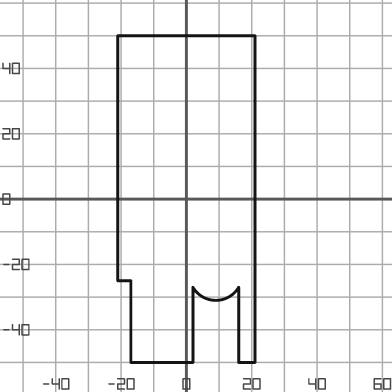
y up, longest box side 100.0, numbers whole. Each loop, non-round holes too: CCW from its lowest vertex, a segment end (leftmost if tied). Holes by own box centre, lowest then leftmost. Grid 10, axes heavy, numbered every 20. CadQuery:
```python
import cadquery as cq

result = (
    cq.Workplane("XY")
    .moveTo(-17.0, -50.0)
    .lineTo(2.0, -50.0)
    .lineTo(2.0, -27.0)
    .threePointArc((9.0, -31.0), (16.0, -27.0))
    .lineTo(16.0, -50.0)
    .lineTo(21.0, -50.0)
    .lineTo(21.0, 50.0)
    .lineTo(-21.0, 50.0)
    .lineTo(-21.0, -25.0)
    .lineTo(-17.0, -25.0)
    .close()
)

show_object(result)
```